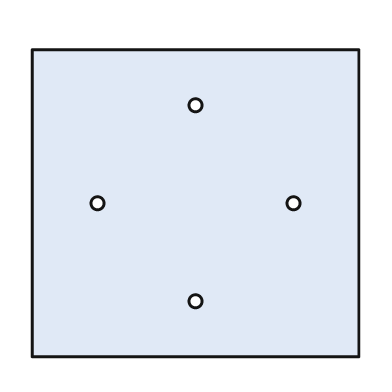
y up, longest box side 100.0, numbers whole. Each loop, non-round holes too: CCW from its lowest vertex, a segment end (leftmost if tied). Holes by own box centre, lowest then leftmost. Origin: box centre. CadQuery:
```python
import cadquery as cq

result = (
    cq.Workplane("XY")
    .moveTo(-50.0, -47.0)
    .lineTo(50.0, -47.0)
    .lineTo(50.0, 47.0)
    .lineTo(-50.0, 47.0)
    .close()
    .moveTo(0.0, -30.0)
    .circle(2.0)
    .moveTo(-30.0, 0.0)
    .circle(2.0)
    .moveTo(30.0, 0.0)
    .circle(2.0)
    .moveTo(0.0, 30.0)
    .circle(2.0)
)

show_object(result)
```